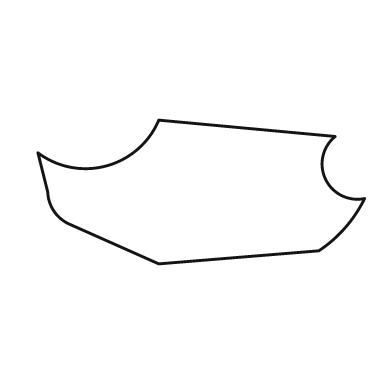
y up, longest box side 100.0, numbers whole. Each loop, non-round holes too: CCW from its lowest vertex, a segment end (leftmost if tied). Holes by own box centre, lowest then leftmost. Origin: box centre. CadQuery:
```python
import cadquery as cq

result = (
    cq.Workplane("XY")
    .moveTo(-13.0, -22.0)
    .lineTo(36.0, -18.0)
    .threePointArc((44.0, -11.0), (50.0, -2.0))
    .threePointArc((38.0, 4.0), (41.0, 17.0))
    .lineTo(-13.0, 22.0)
    .threePointArc((-29.0, 8.0), (-50.0, 12.0))
    .lineTo(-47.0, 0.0)
    .threePointArc((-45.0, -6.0), (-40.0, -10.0))
    .close()
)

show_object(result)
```